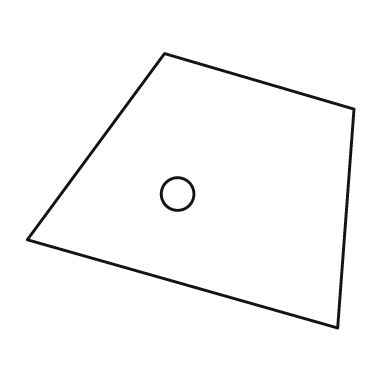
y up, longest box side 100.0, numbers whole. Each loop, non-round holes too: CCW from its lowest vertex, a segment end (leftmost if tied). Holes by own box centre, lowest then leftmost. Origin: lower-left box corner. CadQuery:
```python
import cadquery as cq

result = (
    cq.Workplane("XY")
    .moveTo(95.0, 0.0)
    .lineTo(100.0, 67.0)
    .lineTo(42.0, 84.0)
    .lineTo(0.0, 27.0)
    .close()
    .moveTo(46.0, 41.0)
    .circle(5.0)
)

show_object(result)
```